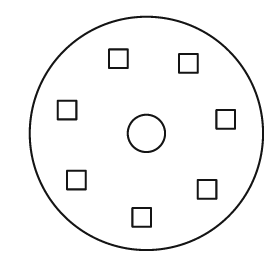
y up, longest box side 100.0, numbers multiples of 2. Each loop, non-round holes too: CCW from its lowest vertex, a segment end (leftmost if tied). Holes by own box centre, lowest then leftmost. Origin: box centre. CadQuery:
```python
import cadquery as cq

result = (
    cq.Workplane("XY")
    .moveTo(0.0, 0.0)
    .circle(50.0)
    .moveTo(-6.0, -40.0)
    .lineTo(2.0, -40.0)
    .lineTo(2.0, -32.0)
    .lineTo(-6.0, -32.0)
    .close()
    .moveTo(22.0, -28.0)
    .lineTo(30.0, -28.0)
    .lineTo(30.0, -20.0)
    .lineTo(22.0, -20.0)
    .close()
    .moveTo(-34.0, -24.0)
    .lineTo(-26.0, -24.0)
    .lineTo(-26.0, -16.0)
    .lineTo(-34.0, -16.0)
    .close()
    .moveTo(0.0, 0.0)
    .circle(8.0)
    .moveTo(30.0, 2.0)
    .lineTo(38.0, 2.0)
    .lineTo(38.0, 10.0)
    .lineTo(30.0, 10.0)
    .close()
    .moveTo(-38.0, 6.0)
    .lineTo(-30.0, 6.0)
    .lineTo(-30.0, 14.0)
    .lineTo(-38.0, 14.0)
    .close()
    .moveTo(14.0, 26.0)
    .lineTo(22.0, 26.0)
    .lineTo(22.0, 34.0)
    .lineTo(14.0, 34.0)
    .close()
    .moveTo(-16.0, 28.0)
    .lineTo(-8.0, 28.0)
    .lineTo(-8.0, 36.0)
    .lineTo(-16.0, 36.0)
    .close()
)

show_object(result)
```